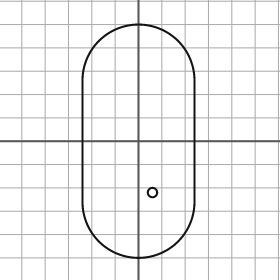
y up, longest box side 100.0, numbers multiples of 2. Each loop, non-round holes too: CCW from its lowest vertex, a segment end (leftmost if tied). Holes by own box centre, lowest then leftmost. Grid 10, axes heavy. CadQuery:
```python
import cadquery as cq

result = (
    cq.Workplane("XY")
    .moveTo(-24.0, -26.0)
    .threePointArc((0.0, -50.0), (24.0, -26.0))
    .lineTo(24.0, 26.0)
    .threePointArc((0.0, 50.0), (-24.0, 26.0))
    .close()
    .moveTo(6.0, -22.0)
    .circle(2.0)
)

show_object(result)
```